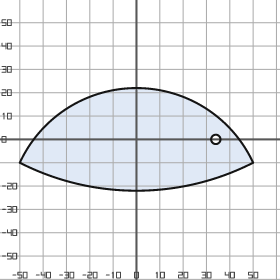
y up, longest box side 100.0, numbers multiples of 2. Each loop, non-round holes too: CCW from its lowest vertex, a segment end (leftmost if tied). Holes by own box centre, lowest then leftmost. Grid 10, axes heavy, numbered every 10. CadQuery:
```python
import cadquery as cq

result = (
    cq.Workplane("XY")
    .moveTo(-50.0, -10.0)
    .threePointArc((0.0, -22.0), (50.0, -10.0))
    .threePointArc((0.0, 22.0), (-50.0, -10.0))
    .close()
    .moveTo(34.0, 0.0)
    .circle(2.0)
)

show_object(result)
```